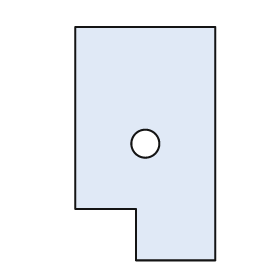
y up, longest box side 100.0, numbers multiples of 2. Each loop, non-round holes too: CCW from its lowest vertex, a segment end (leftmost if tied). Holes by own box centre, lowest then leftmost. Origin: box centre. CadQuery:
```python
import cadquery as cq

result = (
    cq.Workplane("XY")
    .moveTo(-4.0, -50.0)
    .lineTo(30.0, -50.0)
    .lineTo(30.0, 50.0)
    .lineTo(-30.0, 50.0)
    .lineTo(-30.0, -28.0)
    .lineTo(-4.0, -28.0)
    .close()
    .moveTo(0.0, 0.0)
    .circle(6.0)
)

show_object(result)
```